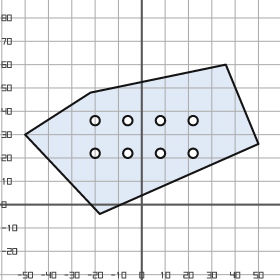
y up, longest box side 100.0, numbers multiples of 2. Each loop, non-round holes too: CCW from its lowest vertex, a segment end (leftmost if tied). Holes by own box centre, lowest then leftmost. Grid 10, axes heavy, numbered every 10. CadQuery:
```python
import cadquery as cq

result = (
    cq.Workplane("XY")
    .moveTo(-18.0, -4.0)
    .lineTo(50.0, 26.0)
    .lineTo(36.0, 60.0)
    .lineTo(-22.0, 48.0)
    .lineTo(-50.0, 30.0)
    .close()
    .moveTo(-20.0, 22.0)
    .circle(2.0)
    .moveTo(-6.0, 22.0)
    .circle(2.0)
    .moveTo(8.0, 22.0)
    .circle(2.0)
    .moveTo(22.0, 22.0)
    .circle(2.0)
    .moveTo(-20.0, 36.0)
    .circle(2.0)
    .moveTo(-6.0, 36.0)
    .circle(2.0)
    .moveTo(8.0, 36.0)
    .circle(2.0)
    .moveTo(22.0, 36.0)
    .circle(2.0)
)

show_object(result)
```